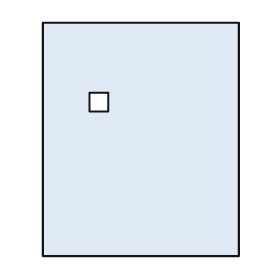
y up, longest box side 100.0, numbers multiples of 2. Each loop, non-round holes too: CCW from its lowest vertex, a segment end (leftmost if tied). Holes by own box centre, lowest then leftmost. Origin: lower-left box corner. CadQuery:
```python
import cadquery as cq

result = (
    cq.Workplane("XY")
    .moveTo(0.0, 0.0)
    .lineTo(84.0, 0.0)
    .lineTo(84.0, 100.0)
    .lineTo(0.0, 100.0)
    .close()
    .moveTo(20.0, 62.0)
    .lineTo(28.0, 62.0)
    .lineTo(28.0, 70.0)
    .lineTo(20.0, 70.0)
    .close()
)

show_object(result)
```